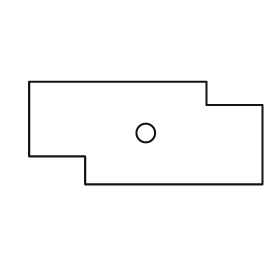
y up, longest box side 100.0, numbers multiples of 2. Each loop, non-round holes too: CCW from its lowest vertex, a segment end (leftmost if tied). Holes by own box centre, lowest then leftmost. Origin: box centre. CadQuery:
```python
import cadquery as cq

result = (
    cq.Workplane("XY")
    .moveTo(-26.0, -22.0)
    .lineTo(50.0, -22.0)
    .lineTo(50.0, 12.0)
    .lineTo(26.0, 12.0)
    .lineTo(26.0, 22.0)
    .lineTo(-50.0, 22.0)
    .lineTo(-50.0, -10.0)
    .lineTo(-26.0, -10.0)
    .close()
    .moveTo(0.0, 0.0)
    .circle(4.0)
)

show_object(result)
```